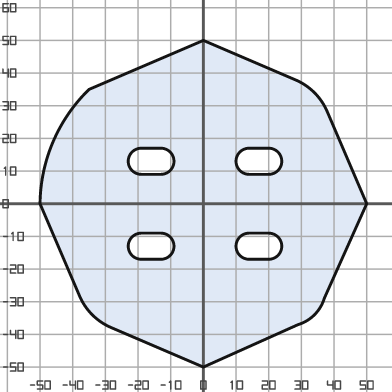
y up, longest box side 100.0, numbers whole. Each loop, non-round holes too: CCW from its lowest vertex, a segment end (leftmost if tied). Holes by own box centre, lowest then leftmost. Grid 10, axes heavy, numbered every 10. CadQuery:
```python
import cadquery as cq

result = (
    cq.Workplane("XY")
    .moveTo(0.0, -50.0)
    .lineTo(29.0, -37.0)
    .threePointArc((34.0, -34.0), (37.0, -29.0))
    .lineTo(50.0, 0.0)
    .lineTo(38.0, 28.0)
    .threePointArc((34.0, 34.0), (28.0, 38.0))
    .lineTo(0.0, 50.0)
    .lineTo(-35.0, 35.0)
    .threePointArc((-46.0, 19.0), (-50.0, 0.0))
    .lineTo(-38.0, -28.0)
    .threePointArc((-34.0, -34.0), (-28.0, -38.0))
    .close()
    .moveTo(-19.0, -17.0)
    .lineTo(-13.0, -17.0)
    .threePointArc((-9.0, -13.0), (-13.0, -9.0))
    .lineTo(-19.0, -9.0)
    .threePointArc((-23.0, -13.0), (-19.0, -17.0))
    .close()
    .moveTo(14.0, -17.0)
    .lineTo(20.0, -17.0)
    .threePointArc((24.0, -13.0), (20.0, -9.0))
    .lineTo(14.0, -9.0)
    .threePointArc((10.0, -13.0), (14.0, -17.0))
    .close()
    .moveTo(-19.0, 9.0)
    .lineTo(-13.0, 9.0)
    .threePointArc((-9.0, 13.0), (-13.0, 17.0))
    .lineTo(-19.0, 17.0)
    .threePointArc((-23.0, 13.0), (-19.0, 9.0))
    .close()
    .moveTo(14.0, 9.0)
    .lineTo(20.0, 9.0)
    .threePointArc((24.0, 13.0), (20.0, 17.0))
    .lineTo(14.0, 17.0)
    .threePointArc((10.0, 13.0), (14.0, 9.0))
    .close()
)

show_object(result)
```